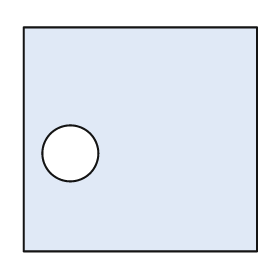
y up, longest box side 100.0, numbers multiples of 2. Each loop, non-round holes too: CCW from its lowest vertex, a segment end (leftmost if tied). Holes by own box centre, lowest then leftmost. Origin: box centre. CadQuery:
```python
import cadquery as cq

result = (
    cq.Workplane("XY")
    .moveTo(-50.0, -48.0)
    .lineTo(50.0, -48.0)
    .lineTo(50.0, 48.0)
    .lineTo(-50.0, 48.0)
    .close()
    .moveTo(-30.0, -6.0)
    .circle(12.0)
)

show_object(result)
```